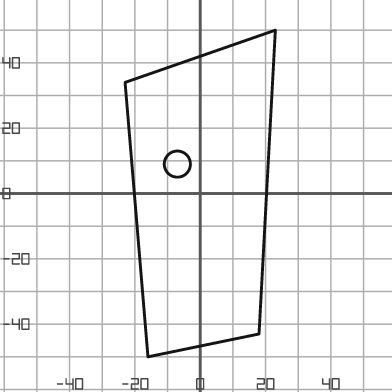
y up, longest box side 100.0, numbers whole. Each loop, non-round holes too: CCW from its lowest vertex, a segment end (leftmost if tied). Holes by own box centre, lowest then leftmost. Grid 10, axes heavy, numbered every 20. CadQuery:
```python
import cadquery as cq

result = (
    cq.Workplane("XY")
    .moveTo(-16.0, -50.0)
    .lineTo(18.0, -43.0)
    .lineTo(23.0, 50.0)
    .lineTo(-23.0, 34.0)
    .close()
    .moveTo(-7.0, 9.0)
    .circle(4.0)
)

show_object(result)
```